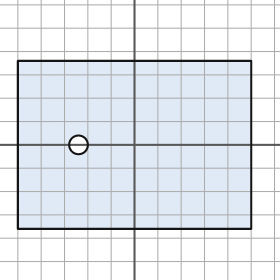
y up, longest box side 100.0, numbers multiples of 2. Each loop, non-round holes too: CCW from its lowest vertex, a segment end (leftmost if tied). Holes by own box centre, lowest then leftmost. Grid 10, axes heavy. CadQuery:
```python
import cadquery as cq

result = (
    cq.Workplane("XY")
    .moveTo(-50.0, -36.0)
    .lineTo(50.0, -36.0)
    .lineTo(50.0, 36.0)
    .lineTo(-50.0, 36.0)
    .close()
    .moveTo(-24.0, 0.0)
    .circle(4.0)
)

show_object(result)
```